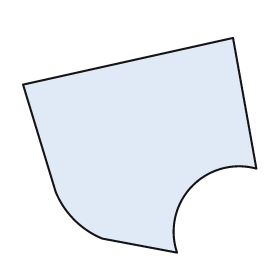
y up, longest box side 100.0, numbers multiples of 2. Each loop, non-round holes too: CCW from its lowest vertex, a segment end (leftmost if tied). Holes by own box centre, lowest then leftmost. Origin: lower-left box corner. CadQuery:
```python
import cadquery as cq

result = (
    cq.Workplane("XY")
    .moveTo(66.0, 0.0)
    .threePointArc((72.0, 28.0), (100.0, 36.0))
    .lineTo(90.0, 92.0)
    .lineTo(0.0, 72.0)
    .lineTo(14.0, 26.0)
    .threePointArc((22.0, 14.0), (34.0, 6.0))
    .close()
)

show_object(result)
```